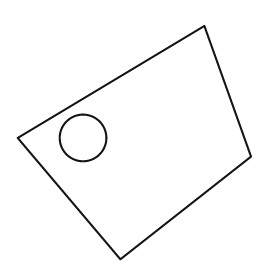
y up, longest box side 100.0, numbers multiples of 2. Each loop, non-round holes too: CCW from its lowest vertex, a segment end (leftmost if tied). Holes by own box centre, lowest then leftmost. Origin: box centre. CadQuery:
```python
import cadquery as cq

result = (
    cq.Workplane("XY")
    .moveTo(-6.0, -50.0)
    .lineTo(50.0, -6.0)
    .lineTo(30.0, 50.0)
    .lineTo(-50.0, 2.0)
    .close()
    .moveTo(-22.0, 2.0)
    .circle(10.0)
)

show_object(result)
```